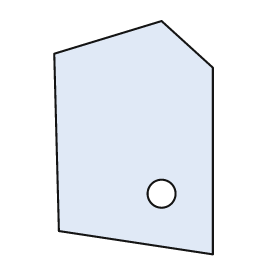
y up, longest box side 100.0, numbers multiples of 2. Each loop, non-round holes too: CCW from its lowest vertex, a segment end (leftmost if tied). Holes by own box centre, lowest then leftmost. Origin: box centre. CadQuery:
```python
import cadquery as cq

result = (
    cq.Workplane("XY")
    .moveTo(34.0, -50.0)
    .lineTo(34.0, 30.0)
    .lineTo(12.0, 50.0)
    .lineTo(-34.0, 36.0)
    .lineTo(-32.0, -40.0)
    .close()
    .moveTo(12.0, -24.0)
    .circle(6.0)
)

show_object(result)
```